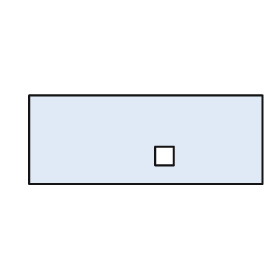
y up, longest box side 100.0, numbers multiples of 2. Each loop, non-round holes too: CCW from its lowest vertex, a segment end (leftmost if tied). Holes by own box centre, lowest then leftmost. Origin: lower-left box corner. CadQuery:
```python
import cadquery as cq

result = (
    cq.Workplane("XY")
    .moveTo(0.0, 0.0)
    .lineTo(100.0, 0.0)
    .lineTo(100.0, 38.0)
    .lineTo(0.0, 38.0)
    .close()
    .moveTo(54.0, 8.0)
    .lineTo(62.0, 8.0)
    .lineTo(62.0, 16.0)
    .lineTo(54.0, 16.0)
    .close()
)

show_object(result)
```